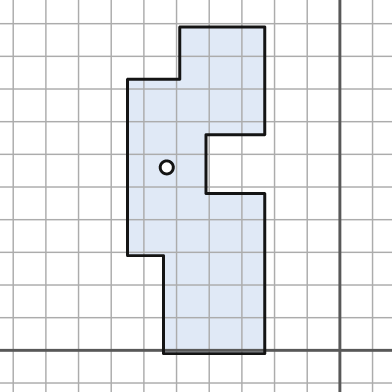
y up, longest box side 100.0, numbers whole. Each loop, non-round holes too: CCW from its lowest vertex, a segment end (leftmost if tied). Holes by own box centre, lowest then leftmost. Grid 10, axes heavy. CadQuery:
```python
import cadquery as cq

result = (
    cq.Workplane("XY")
    .moveTo(-54.0, -1.0)
    .lineTo(-23.0, -1.0)
    .lineTo(-23.0, 48.0)
    .lineTo(-41.0, 48.0)
    .lineTo(-41.0, 66.0)
    .lineTo(-23.0, 66.0)
    .lineTo(-23.0, 99.0)
    .lineTo(-49.0, 99.0)
    .lineTo(-49.0, 83.0)
    .lineTo(-65.0, 83.0)
    .lineTo(-65.0, 29.0)
    .lineTo(-54.0, 29.0)
    .close()
    .moveTo(-53.0, 56.0)
    .circle(2.0)
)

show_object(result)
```